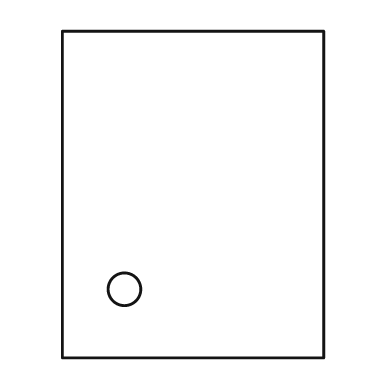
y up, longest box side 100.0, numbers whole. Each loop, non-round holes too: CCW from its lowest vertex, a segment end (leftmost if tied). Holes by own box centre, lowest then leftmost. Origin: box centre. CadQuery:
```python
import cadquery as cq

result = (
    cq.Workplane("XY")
    .moveTo(-40.0, -50.0)
    .lineTo(40.0, -50.0)
    .lineTo(40.0, 50.0)
    .lineTo(-40.0, 50.0)
    .close()
    .moveTo(-21.0, -29.0)
    .circle(5.0)
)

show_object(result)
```